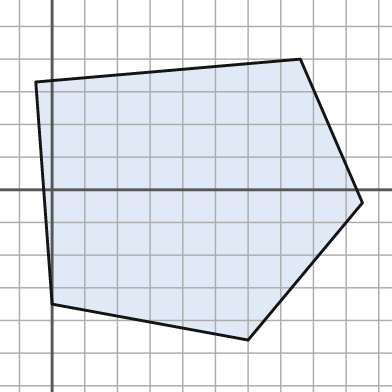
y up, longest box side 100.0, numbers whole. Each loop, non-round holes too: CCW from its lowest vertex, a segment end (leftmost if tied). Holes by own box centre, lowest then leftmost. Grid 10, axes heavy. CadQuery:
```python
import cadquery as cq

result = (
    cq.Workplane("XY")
    .moveTo(60.0, -46.0)
    .lineTo(95.0, -4.0)
    .lineTo(76.0, 40.0)
    .lineTo(-5.0, 33.0)
    .lineTo(0.0, -35.0)
    .close()
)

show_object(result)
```